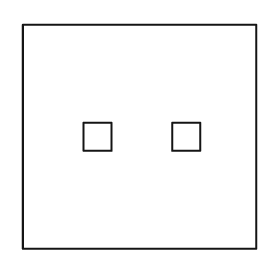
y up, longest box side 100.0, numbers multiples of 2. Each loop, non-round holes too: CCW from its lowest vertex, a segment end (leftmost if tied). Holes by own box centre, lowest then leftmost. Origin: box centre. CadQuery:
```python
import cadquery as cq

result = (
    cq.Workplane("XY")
    .moveTo(-50.0, -48.0)
    .lineTo(50.0, -48.0)
    .lineTo(50.0, 48.0)
    .lineTo(-50.0, 48.0)
    .close()
    .moveTo(-24.0, -6.0)
    .lineTo(-12.0, -6.0)
    .lineTo(-12.0, 6.0)
    .lineTo(-24.0, 6.0)
    .close()
    .moveTo(14.0, -6.0)
    .lineTo(26.0, -6.0)
    .lineTo(26.0, 6.0)
    .lineTo(14.0, 6.0)
    .close()
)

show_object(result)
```